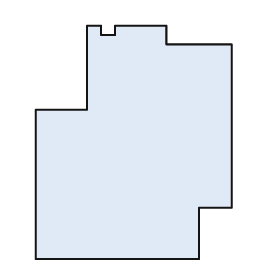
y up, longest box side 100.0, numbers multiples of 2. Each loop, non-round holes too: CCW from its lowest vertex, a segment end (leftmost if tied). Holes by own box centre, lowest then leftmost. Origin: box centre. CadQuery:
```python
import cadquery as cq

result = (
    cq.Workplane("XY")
    .moveTo(-42.0, -50.0)
    .lineTo(28.0, -50.0)
    .lineTo(28.0, -28.0)
    .lineTo(42.0, -28.0)
    .lineTo(42.0, 42.0)
    .lineTo(14.0, 42.0)
    .lineTo(14.0, 50.0)
    .lineTo(-8.0, 50.0)
    .lineTo(-8.0, 46.0)
    .lineTo(-14.0, 46.0)
    .lineTo(-14.0, 50.0)
    .lineTo(-20.0, 50.0)
    .lineTo(-20.0, 14.0)
    .lineTo(-42.0, 14.0)
    .close()
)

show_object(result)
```